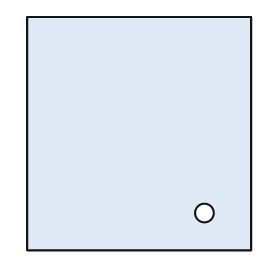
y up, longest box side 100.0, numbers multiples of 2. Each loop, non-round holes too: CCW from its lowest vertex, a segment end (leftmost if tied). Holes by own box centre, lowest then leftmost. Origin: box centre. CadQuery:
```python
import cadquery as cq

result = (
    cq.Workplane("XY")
    .moveTo(-48.0, -50.0)
    .lineTo(48.0, -50.0)
    .lineTo(48.0, 50.0)
    .lineTo(-48.0, 50.0)
    .close()
    .moveTo(28.0, -34.0)
    .circle(4.0)
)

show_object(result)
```